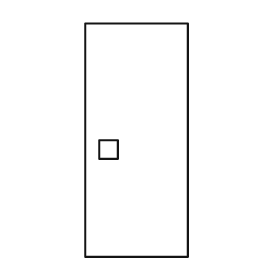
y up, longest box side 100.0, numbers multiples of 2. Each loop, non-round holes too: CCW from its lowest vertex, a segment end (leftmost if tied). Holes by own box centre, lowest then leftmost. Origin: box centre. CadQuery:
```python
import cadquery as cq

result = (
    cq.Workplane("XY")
    .moveTo(-22.0, -50.0)
    .lineTo(22.0, -50.0)
    .lineTo(22.0, 50.0)
    .lineTo(-22.0, 50.0)
    .close()
    .moveTo(-16.0, -8.0)
    .lineTo(-8.0, -8.0)
    .lineTo(-8.0, 0.0)
    .lineTo(-16.0, 0.0)
    .close()
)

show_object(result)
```